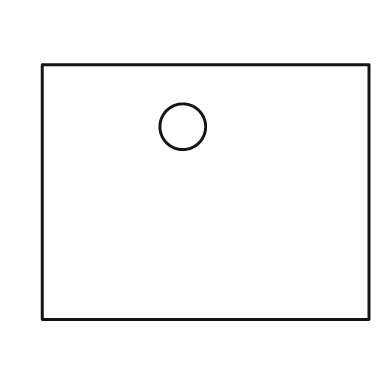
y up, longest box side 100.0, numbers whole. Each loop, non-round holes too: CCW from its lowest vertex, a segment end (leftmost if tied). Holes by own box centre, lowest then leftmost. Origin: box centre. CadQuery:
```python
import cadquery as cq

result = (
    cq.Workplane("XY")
    .moveTo(-50.0, -39.0)
    .lineTo(50.0, -39.0)
    .lineTo(50.0, 39.0)
    .lineTo(-50.0, 39.0)
    .close()
    .moveTo(-7.0, 20.0)
    .circle(7.0)
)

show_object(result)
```